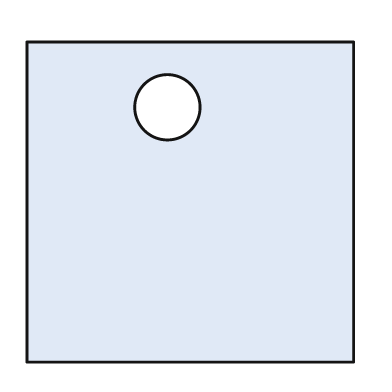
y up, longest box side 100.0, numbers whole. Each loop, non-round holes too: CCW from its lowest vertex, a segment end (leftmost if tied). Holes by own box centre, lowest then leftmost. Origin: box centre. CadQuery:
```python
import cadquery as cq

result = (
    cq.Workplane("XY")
    .moveTo(-50.0, -49.0)
    .lineTo(50.0, -49.0)
    .lineTo(50.0, 49.0)
    .lineTo(-50.0, 49.0)
    .close()
    .moveTo(-7.0, 29.0)
    .circle(10.0)
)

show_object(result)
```